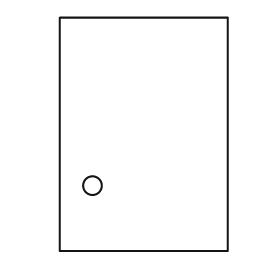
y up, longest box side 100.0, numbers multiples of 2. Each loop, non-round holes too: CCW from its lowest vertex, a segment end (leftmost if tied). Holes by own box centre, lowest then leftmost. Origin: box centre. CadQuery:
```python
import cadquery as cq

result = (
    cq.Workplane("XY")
    .moveTo(-36.0, -50.0)
    .lineTo(36.0, -50.0)
    .lineTo(36.0, 50.0)
    .lineTo(-36.0, 50.0)
    .close()
    .moveTo(-22.0, -22.0)
    .circle(4.0)
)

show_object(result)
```